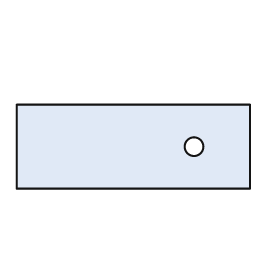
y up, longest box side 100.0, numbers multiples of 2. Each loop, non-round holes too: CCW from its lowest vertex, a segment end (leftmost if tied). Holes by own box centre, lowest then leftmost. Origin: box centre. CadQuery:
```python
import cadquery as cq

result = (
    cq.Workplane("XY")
    .moveTo(-50.0, -18.0)
    .lineTo(50.0, -18.0)
    .lineTo(50.0, 18.0)
    .lineTo(-50.0, 18.0)
    .close()
    .moveTo(26.0, 0.0)
    .circle(4.0)
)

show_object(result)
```